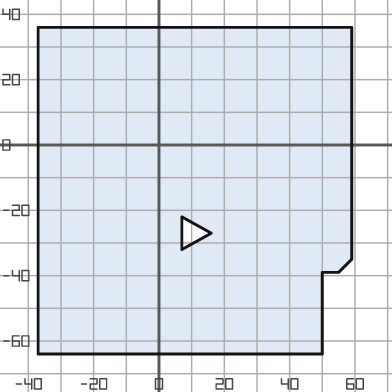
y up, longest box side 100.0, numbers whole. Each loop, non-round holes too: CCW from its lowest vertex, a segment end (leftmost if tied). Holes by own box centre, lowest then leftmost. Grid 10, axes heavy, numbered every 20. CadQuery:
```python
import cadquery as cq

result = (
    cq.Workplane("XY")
    .moveTo(-37.0, -64.0)
    .lineTo(50.0, -64.0)
    .lineTo(50.0, -39.0)
    .lineTo(55.0, -39.0)
    .lineTo(59.0, -35.0)
    .lineTo(59.0, 36.0)
    .lineTo(-37.0, 36.0)
    .close()
    .moveTo(7.0, -32.0)
    .lineTo(16.0, -27.0)
    .lineTo(7.0, -22.0)
    .close()
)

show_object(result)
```